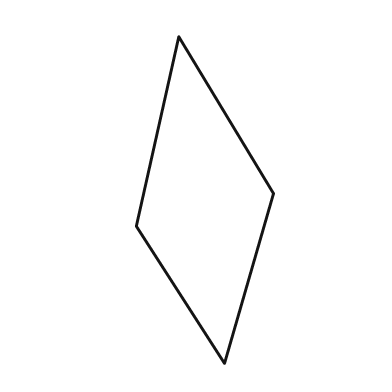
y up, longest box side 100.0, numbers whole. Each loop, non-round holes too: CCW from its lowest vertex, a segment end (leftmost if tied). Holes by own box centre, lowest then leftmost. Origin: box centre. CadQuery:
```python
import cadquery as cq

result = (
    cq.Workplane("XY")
    .moveTo(6.0, -50.0)
    .lineTo(21.0, 2.0)
    .lineTo(-8.0, 50.0)
    .lineTo(-21.0, -8.0)
    .close()
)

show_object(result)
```